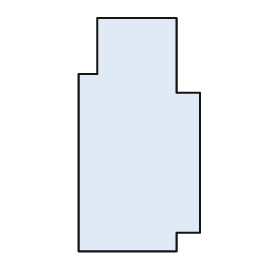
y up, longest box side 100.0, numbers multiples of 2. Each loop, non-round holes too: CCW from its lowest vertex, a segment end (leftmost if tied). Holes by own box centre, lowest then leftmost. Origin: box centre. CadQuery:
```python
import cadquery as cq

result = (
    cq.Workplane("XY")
    .moveTo(-26.0, -50.0)
    .lineTo(16.0, -50.0)
    .lineTo(16.0, -42.0)
    .lineTo(26.0, -42.0)
    .lineTo(26.0, 18.0)
    .lineTo(16.0, 18.0)
    .lineTo(16.0, 50.0)
    .lineTo(-18.0, 50.0)
    .lineTo(-18.0, 26.0)
    .lineTo(-26.0, 26.0)
    .close()
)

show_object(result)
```